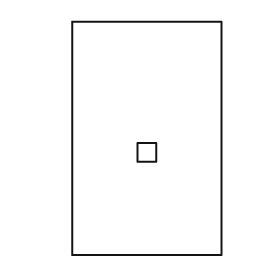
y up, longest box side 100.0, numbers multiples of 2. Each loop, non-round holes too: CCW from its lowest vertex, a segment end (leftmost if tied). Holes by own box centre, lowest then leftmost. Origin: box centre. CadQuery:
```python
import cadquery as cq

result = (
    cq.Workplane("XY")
    .moveTo(-32.0, -50.0)
    .lineTo(32.0, -50.0)
    .lineTo(32.0, 50.0)
    .lineTo(-32.0, 50.0)
    .close()
    .moveTo(-4.0, -10.0)
    .lineTo(4.0, -10.0)
    .lineTo(4.0, -2.0)
    .lineTo(-4.0, -2.0)
    .close()
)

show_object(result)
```